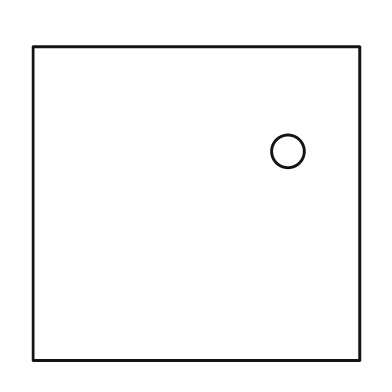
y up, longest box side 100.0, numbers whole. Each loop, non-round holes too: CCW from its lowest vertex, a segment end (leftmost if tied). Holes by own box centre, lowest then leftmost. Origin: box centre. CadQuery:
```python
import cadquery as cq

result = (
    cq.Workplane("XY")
    .moveTo(-50.0, -48.0)
    .lineTo(50.0, -48.0)
    .lineTo(50.0, 48.0)
    .lineTo(-50.0, 48.0)
    .close()
    .moveTo(28.0, 16.0)
    .circle(5.0)
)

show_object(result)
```